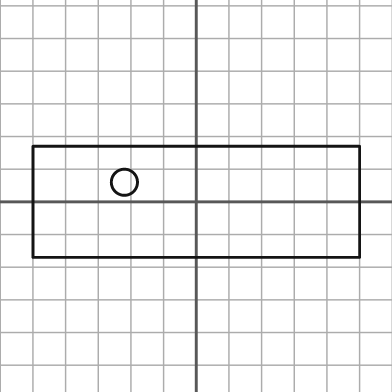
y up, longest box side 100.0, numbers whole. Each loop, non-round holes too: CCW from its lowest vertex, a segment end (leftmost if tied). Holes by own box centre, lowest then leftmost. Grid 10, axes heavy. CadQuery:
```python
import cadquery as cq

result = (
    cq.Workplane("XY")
    .moveTo(-50.0, -17.0)
    .lineTo(50.0, -17.0)
    .lineTo(50.0, 17.0)
    .lineTo(-50.0, 17.0)
    .close()
    .moveTo(-22.0, 6.0)
    .circle(4.0)
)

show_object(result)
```